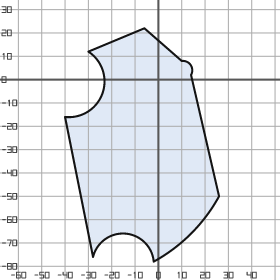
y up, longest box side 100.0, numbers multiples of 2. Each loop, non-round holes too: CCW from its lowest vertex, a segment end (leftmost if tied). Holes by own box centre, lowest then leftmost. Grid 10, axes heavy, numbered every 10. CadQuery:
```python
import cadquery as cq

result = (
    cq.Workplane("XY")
    .moveTo(-2.0, -78.0)
    .threePointArc((14.0, -66.0), (26.0, -50.0))
    .lineTo(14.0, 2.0)
    .threePointArc((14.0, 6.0), (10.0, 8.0))
    .lineTo(-6.0, 22.0)
    .lineTo(-30.0, 12.0)
    .threePointArc((-24.0, -6.0), (-40.0, -16.0))
    .lineTo(-28.0, -76.0)
    .threePointArc((-14.0, -66.0), (-2.0, -78.0))
    .close()
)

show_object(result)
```